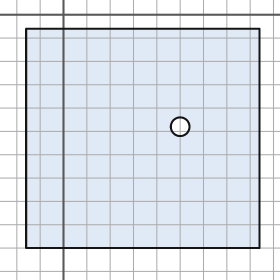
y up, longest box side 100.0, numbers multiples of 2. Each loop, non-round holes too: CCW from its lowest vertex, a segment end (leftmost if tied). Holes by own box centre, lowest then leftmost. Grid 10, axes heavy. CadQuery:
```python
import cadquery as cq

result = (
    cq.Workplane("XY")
    .moveTo(-16.0, -100.0)
    .lineTo(84.0, -100.0)
    .lineTo(84.0, -6.0)
    .lineTo(-16.0, -6.0)
    .close()
    .moveTo(50.0, -48.0)
    .circle(4.0)
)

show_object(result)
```